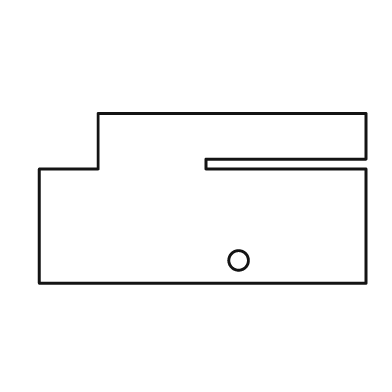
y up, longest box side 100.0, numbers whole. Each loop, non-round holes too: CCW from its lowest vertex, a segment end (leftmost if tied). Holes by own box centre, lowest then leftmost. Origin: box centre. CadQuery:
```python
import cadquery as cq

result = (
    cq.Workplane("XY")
    .moveTo(-50.0, -26.0)
    .lineTo(50.0, -26.0)
    .lineTo(50.0, 9.0)
    .lineTo(1.0, 9.0)
    .lineTo(1.0, 12.0)
    .lineTo(50.0, 12.0)
    .lineTo(50.0, 26.0)
    .lineTo(-32.0, 26.0)
    .lineTo(-32.0, 9.0)
    .lineTo(-50.0, 9.0)
    .close()
    .moveTo(11.0, -19.0)
    .circle(3.0)
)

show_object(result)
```